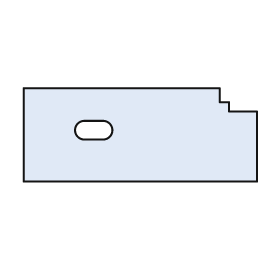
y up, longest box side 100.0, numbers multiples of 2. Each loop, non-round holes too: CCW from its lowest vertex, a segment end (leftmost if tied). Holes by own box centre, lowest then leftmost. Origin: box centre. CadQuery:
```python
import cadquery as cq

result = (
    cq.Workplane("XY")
    .moveTo(-50.0, -20.0)
    .lineTo(50.0, -20.0)
    .lineTo(50.0, 10.0)
    .lineTo(38.0, 10.0)
    .lineTo(38.0, 14.0)
    .lineTo(34.0, 14.0)
    .lineTo(34.0, 20.0)
    .lineTo(-50.0, 20.0)
    .close()
    .moveTo(-24.0, -2.0)
    .lineTo(-16.0, -2.0)
    .threePointArc((-12.0, 2.0), (-16.0, 6.0))
    .lineTo(-24.0, 6.0)
    .threePointArc((-28.0, 2.0), (-24.0, -2.0))
    .close()
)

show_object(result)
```